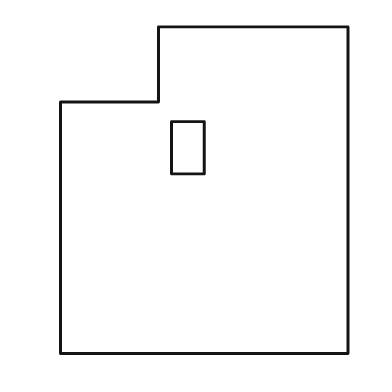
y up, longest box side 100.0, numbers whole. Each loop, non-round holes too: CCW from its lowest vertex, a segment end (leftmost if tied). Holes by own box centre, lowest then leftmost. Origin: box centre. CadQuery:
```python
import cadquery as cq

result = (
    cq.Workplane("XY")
    .moveTo(-44.0, -50.0)
    .lineTo(44.0, -50.0)
    .lineTo(44.0, 50.0)
    .lineTo(-14.0, 50.0)
    .lineTo(-14.0, 27.0)
    .lineTo(-44.0, 27.0)
    .close()
    .moveTo(-10.0, 5.0)
    .lineTo(0.0, 5.0)
    .lineTo(0.0, 21.0)
    .lineTo(-10.0, 21.0)
    .close()
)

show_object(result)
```